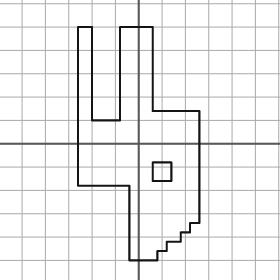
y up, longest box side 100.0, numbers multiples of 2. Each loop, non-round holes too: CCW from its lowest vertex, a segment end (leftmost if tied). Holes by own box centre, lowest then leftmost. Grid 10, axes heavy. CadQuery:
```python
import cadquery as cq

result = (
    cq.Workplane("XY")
    .moveTo(-4.0, -50.0)
    .lineTo(8.0, -50.0)
    .lineTo(8.0, -46.0)
    .lineTo(12.0, -46.0)
    .lineTo(12.0, -42.0)
    .lineTo(18.0, -42.0)
    .lineTo(18.0, -38.0)
    .lineTo(22.0, -38.0)
    .lineTo(22.0, -34.0)
    .lineTo(26.0, -34.0)
    .lineTo(26.0, 14.0)
    .lineTo(6.0, 14.0)
    .lineTo(6.0, 50.0)
    .lineTo(-8.0, 50.0)
    .lineTo(-8.0, 10.0)
    .lineTo(-20.0, 10.0)
    .lineTo(-20.0, 50.0)
    .lineTo(-26.0, 50.0)
    .lineTo(-26.0, -18.0)
    .lineTo(-4.0, -18.0)
    .close()
    .moveTo(6.0, -16.0)
    .lineTo(14.0, -16.0)
    .lineTo(14.0, -8.0)
    .lineTo(6.0, -8.0)
    .close()
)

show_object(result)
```